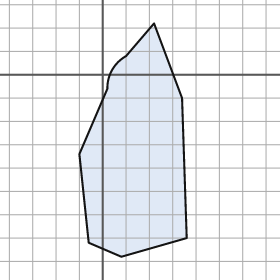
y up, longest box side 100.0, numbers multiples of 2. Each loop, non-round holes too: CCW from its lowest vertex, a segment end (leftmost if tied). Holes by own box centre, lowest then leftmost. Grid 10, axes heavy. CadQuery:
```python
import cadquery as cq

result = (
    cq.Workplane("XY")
    .moveTo(8.0, -78.0)
    .lineTo(36.0, -70.0)
    .lineTo(34.0, -10.0)
    .lineTo(22.0, 22.0)
    .lineTo(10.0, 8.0)
    .threePointArc((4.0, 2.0), (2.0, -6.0))
    .lineTo(-10.0, -34.0)
    .lineTo(-6.0, -72.0)
    .close()
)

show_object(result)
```